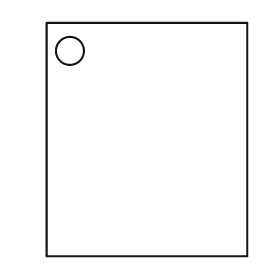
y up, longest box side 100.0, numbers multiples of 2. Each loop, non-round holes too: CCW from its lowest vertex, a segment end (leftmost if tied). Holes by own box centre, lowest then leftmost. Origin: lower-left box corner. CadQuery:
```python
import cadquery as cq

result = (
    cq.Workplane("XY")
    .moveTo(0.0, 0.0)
    .lineTo(86.0, 0.0)
    .lineTo(86.0, 100.0)
    .lineTo(0.0, 100.0)
    .close()
    .moveTo(10.0, 88.0)
    .circle(6.0)
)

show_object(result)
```